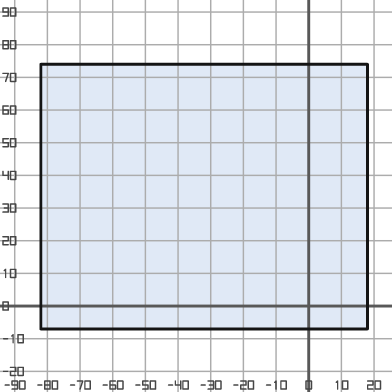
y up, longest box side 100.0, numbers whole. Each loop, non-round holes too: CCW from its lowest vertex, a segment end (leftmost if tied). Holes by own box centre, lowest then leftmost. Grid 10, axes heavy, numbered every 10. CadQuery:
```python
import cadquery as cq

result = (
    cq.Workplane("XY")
    .moveTo(-82.0, -7.0)
    .lineTo(18.0, -7.0)
    .lineTo(18.0, 74.0)
    .lineTo(-82.0, 74.0)
    .close()
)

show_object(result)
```